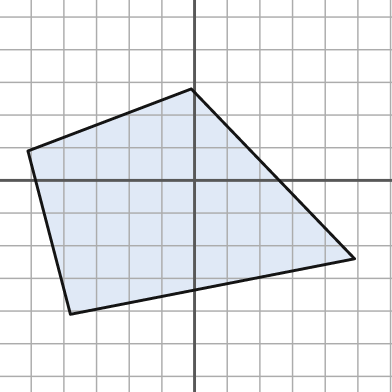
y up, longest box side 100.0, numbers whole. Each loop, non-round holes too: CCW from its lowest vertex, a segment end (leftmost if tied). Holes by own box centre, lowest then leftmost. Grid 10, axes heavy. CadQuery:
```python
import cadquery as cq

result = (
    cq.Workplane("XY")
    .moveTo(-38.0, -41.0)
    .lineTo(49.0, -24.0)
    .lineTo(-1.0, 28.0)
    .lineTo(-51.0, 9.0)
    .close()
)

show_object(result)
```